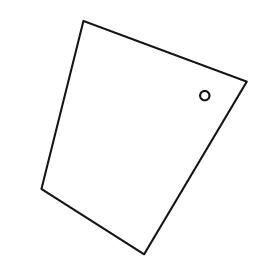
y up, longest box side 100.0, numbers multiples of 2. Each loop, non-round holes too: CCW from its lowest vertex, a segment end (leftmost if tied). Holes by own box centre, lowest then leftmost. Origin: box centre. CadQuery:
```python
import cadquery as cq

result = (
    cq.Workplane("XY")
    .moveTo(0.0, -50.0)
    .lineTo(44.0, 24.0)
    .lineTo(-26.0, 50.0)
    .lineTo(-44.0, -22.0)
    .close()
    .moveTo(26.0, 18.0)
    .circle(2.0)
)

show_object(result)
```